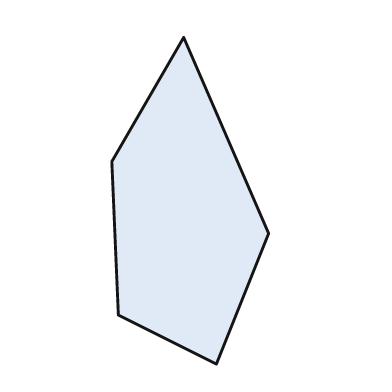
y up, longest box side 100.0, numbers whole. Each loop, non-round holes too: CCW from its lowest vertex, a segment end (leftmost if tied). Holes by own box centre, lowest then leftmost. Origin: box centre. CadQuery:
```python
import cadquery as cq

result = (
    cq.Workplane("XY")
    .moveTo(8.0, -50.0)
    .lineTo(24.0, -10.0)
    .lineTo(-2.0, 50.0)
    .lineTo(-24.0, 12.0)
    .lineTo(-22.0, -35.0)
    .close()
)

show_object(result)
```